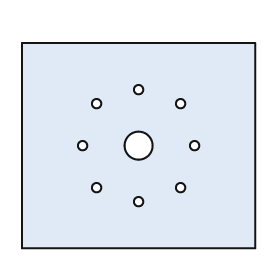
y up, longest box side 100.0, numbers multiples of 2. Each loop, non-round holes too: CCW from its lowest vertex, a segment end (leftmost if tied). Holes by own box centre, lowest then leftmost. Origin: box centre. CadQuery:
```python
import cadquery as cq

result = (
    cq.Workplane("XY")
    .moveTo(-50.0, -44.0)
    .lineTo(50.0, -44.0)
    .lineTo(50.0, 44.0)
    .lineTo(-50.0, 44.0)
    .close()
    .moveTo(0.0, -24.0)
    .circle(2.0)
    .moveTo(-18.0, -18.0)
    .circle(2.0)
    .moveTo(18.0, -18.0)
    .circle(2.0)
    .moveTo(-24.0, 0.0)
    .circle(2.0)
    .moveTo(0.0, 0.0)
    .circle(6.0)
    .moveTo(24.0, 0.0)
    .circle(2.0)
    .moveTo(-18.0, 18.0)
    .circle(2.0)
    .moveTo(18.0, 18.0)
    .circle(2.0)
    .moveTo(0.0, 24.0)
    .circle(2.0)
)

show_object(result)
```